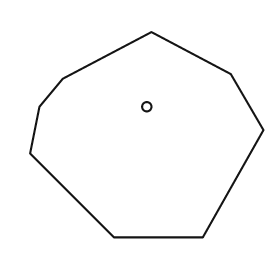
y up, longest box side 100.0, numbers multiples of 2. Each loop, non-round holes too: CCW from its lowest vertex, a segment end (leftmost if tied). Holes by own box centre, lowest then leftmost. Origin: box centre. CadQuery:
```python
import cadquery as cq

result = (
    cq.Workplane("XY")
    .moveTo(-14.0, -44.0)
    .lineTo(24.0, -44.0)
    .lineTo(50.0, 2.0)
    .lineTo(36.0, 26.0)
    .lineTo(2.0, 44.0)
    .lineTo(-36.0, 24.0)
    .lineTo(-46.0, 12.0)
    .lineTo(-50.0, -8.0)
    .close()
    .moveTo(0.0, 12.0)
    .circle(2.0)
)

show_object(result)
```